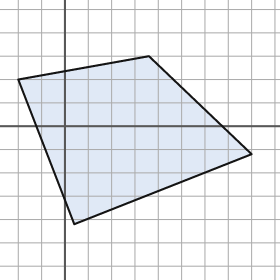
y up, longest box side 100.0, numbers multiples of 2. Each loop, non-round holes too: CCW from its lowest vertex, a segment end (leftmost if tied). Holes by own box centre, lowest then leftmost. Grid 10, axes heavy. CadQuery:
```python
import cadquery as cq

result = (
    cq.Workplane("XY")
    .moveTo(4.0, -42.0)
    .lineTo(80.0, -12.0)
    .lineTo(36.0, 30.0)
    .lineTo(-20.0, 20.0)
    .close()
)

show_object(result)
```